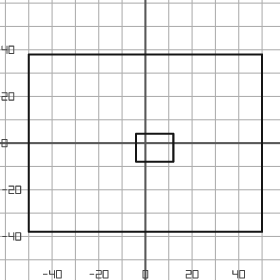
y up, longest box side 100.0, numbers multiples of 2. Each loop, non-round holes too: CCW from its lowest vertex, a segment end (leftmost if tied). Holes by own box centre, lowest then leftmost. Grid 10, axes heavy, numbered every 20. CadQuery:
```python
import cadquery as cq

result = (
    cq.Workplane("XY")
    .moveTo(-50.0, -38.0)
    .lineTo(50.0, -38.0)
    .lineTo(50.0, 38.0)
    .lineTo(-50.0, 38.0)
    .close()
    .moveTo(-4.0, -8.0)
    .lineTo(12.0, -8.0)
    .lineTo(12.0, 4.0)
    .lineTo(-4.0, 4.0)
    .close()
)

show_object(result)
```